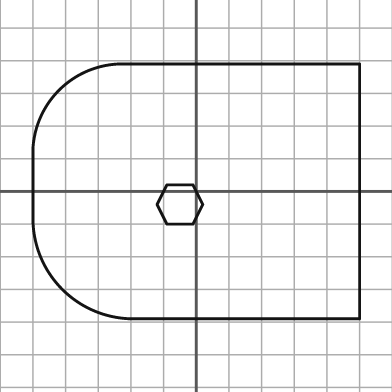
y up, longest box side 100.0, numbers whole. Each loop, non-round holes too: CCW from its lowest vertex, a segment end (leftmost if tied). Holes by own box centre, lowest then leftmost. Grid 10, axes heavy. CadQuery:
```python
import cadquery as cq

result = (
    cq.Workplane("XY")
    .moveTo(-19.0, -39.0)
    .lineTo(50.0, -39.0)
    .lineTo(50.0, 39.0)
    .lineTo(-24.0, 39.0)
    .threePointArc((-42.0, 31.0), (-50.0, 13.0))
    .lineTo(-50.0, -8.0)
    .threePointArc((-41.0, -30.0), (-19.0, -39.0))
    .close()
    .moveTo(-9.0, -10.0)
    .lineTo(-1.0, -10.0)
    .lineTo(2.0, -4.0)
    .lineTo(-1.0, 2.0)
    .lineTo(-9.0, 2.0)
    .lineTo(-12.0, -4.0)
    .close()
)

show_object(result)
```